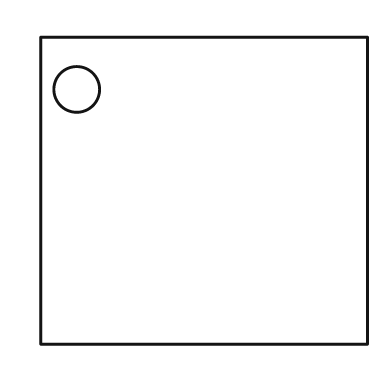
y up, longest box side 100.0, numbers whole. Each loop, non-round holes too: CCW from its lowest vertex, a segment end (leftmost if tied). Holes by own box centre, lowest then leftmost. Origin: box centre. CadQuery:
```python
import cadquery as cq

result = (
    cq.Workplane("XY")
    .moveTo(-50.0, -47.0)
    .lineTo(50.0, -47.0)
    .lineTo(50.0, 47.0)
    .lineTo(-50.0, 47.0)
    .close()
    .moveTo(-39.0, 31.0)
    .circle(7.0)
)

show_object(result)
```